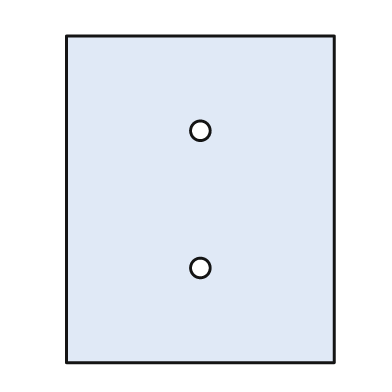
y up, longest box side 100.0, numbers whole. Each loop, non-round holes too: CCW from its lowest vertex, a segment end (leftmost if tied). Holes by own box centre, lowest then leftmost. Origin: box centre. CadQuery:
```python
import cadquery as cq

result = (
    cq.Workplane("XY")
    .moveTo(-41.0, -50.0)
    .lineTo(41.0, -50.0)
    .lineTo(41.0, 50.0)
    .lineTo(-41.0, 50.0)
    .close()
    .moveTo(0.0, -21.0)
    .circle(3.0)
    .moveTo(0.0, 21.0)
    .circle(3.0)
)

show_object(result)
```